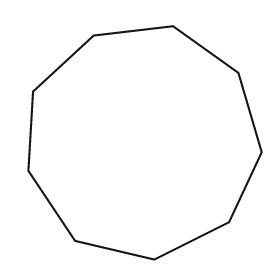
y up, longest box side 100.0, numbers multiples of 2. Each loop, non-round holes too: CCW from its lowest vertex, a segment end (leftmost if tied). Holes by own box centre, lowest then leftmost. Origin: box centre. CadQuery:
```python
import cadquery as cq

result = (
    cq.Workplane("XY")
    .moveTo(4.0, -50.0)
    .lineTo(36.0, -34.0)
    .lineTo(50.0, -4.0)
    .lineTo(40.0, 30.0)
    .lineTo(12.0, 50.0)
    .lineTo(-22.0, 46.0)
    .lineTo(-48.0, 22.0)
    .lineTo(-50.0, -12.0)
    .lineTo(-30.0, -42.0)
    .close()
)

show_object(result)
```